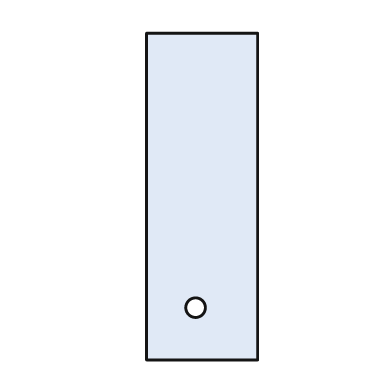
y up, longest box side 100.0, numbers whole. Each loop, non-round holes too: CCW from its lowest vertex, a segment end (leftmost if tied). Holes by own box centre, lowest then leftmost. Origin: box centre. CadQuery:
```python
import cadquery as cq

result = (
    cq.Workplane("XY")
    .moveTo(-17.0, -50.0)
    .lineTo(17.0, -50.0)
    .lineTo(17.0, 50.0)
    .lineTo(-17.0, 50.0)
    .close()
    .moveTo(-2.0, -34.0)
    .circle(3.0)
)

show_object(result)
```